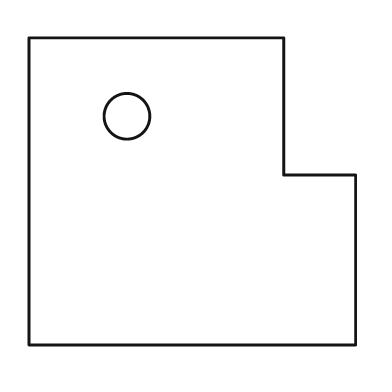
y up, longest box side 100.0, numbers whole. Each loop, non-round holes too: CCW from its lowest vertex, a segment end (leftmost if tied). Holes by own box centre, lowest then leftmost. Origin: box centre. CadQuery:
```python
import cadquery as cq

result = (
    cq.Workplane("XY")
    .moveTo(-50.0, -47.0)
    .lineTo(50.0, -47.0)
    .lineTo(50.0, 5.0)
    .lineTo(28.0, 5.0)
    .lineTo(28.0, 47.0)
    .lineTo(-50.0, 47.0)
    .close()
    .moveTo(-20.0, 23.0)
    .circle(7.0)
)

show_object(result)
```